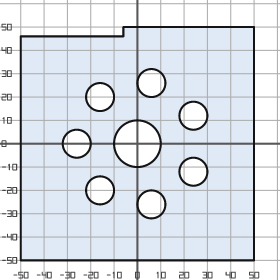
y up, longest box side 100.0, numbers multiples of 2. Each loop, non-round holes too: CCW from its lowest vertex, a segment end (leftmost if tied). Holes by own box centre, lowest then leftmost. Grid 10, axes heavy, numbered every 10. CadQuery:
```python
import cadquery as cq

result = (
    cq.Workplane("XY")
    .moveTo(-50.0, -50.0)
    .lineTo(50.0, -50.0)
    .lineTo(50.0, 50.0)
    .lineTo(-6.0, 50.0)
    .lineTo(-6.0, 46.0)
    .lineTo(-50.0, 46.0)
    .close()
    .moveTo(6.0, -26.0)
    .circle(6.0)
    .moveTo(-16.0, -20.0)
    .circle(6.0)
    .moveTo(24.0, -12.0)
    .circle(6.0)
    .moveTo(-26.0, 0.0)
    .circle(6.0)
    .moveTo(0.0, 0.0)
    .circle(10.0)
    .moveTo(24.0, 12.0)
    .circle(6.0)
    .moveTo(-16.0, 20.0)
    .circle(6.0)
    .moveTo(6.0, 26.0)
    .circle(6.0)
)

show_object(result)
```